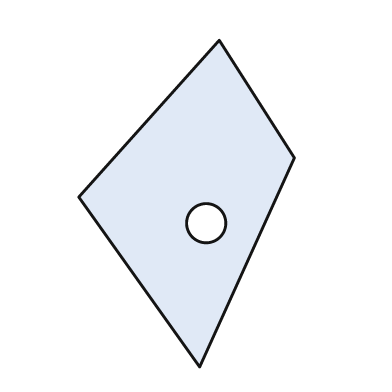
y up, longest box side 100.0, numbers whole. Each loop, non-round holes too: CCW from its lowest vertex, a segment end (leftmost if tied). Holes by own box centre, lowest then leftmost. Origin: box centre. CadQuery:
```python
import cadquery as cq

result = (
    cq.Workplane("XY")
    .moveTo(4.0, -50.0)
    .lineTo(33.0, 14.0)
    .lineTo(10.0, 50.0)
    .lineTo(-33.0, 2.0)
    .close()
    .moveTo(6.0, -6.0)
    .circle(6.0)
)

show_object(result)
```